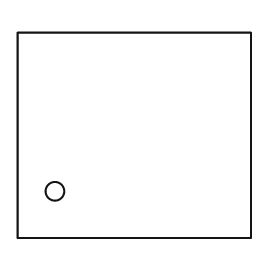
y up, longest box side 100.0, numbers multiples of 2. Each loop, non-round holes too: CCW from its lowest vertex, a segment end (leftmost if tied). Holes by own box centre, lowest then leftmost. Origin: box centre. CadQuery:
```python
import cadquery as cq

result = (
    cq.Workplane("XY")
    .moveTo(-50.0, -44.0)
    .lineTo(50.0, -44.0)
    .lineTo(50.0, 44.0)
    .lineTo(-50.0, 44.0)
    .close()
    .moveTo(-34.0, -24.0)
    .circle(4.0)
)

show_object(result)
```